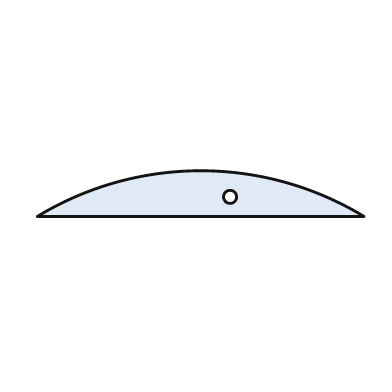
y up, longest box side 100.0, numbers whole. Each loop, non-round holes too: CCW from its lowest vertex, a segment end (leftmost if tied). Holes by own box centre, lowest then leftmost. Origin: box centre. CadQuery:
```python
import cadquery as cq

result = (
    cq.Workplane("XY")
    .moveTo(-50.0, -7.0)
    .lineTo(50.0, -7.0)
    .threePointArc((0.0, 7.0), (-50.0, -7.0))
    .close()
    .moveTo(9.0, -1.0)
    .circle(2.0)
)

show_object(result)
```